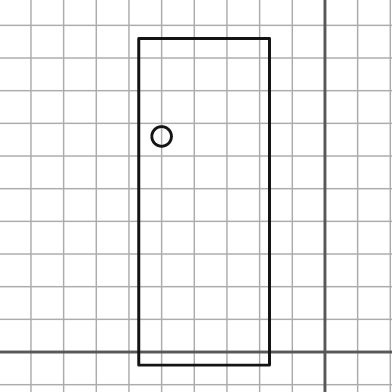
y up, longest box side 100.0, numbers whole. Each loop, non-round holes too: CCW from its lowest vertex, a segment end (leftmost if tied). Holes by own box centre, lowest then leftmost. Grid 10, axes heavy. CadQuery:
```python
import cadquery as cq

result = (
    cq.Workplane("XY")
    .moveTo(-57.0, -4.0)
    .lineTo(-17.0, -4.0)
    .lineTo(-17.0, 96.0)
    .lineTo(-57.0, 96.0)
    .close()
    .moveTo(-50.0, 66.0)
    .circle(3.0)
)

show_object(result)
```